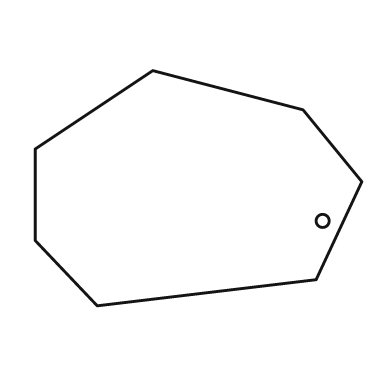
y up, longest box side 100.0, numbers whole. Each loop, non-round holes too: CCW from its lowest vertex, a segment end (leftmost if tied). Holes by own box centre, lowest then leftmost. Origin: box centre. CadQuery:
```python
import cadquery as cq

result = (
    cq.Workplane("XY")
    .moveTo(-31.0, -36.0)
    .lineTo(36.0, -28.0)
    .lineTo(50.0, 2.0)
    .lineTo(32.0, 24.0)
    .lineTo(-14.0, 36.0)
    .lineTo(-50.0, 12.0)
    .lineTo(-50.0, -16.0)
    .close()
    .moveTo(38.0, -10.0)
    .circle(2.0)
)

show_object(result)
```